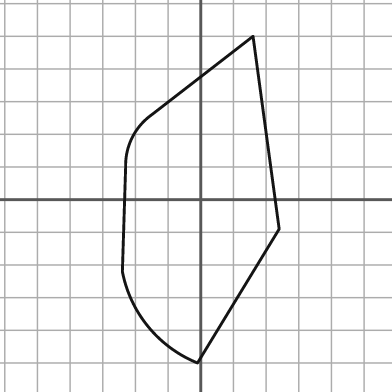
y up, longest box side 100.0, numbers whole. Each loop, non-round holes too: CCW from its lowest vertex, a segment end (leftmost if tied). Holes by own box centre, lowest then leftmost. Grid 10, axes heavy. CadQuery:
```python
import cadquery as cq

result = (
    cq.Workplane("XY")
    .moveTo(-1.0, -50.0)
    .lineTo(24.0, -9.0)
    .lineTo(16.0, 50.0)
    .lineTo(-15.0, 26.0)
    .threePointArc((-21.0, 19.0), (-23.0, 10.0))
    .lineTo(-24.0, -22.0)
    .threePointArc((-16.0, -39.0), (-1.0, -50.0))
    .close()
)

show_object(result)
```